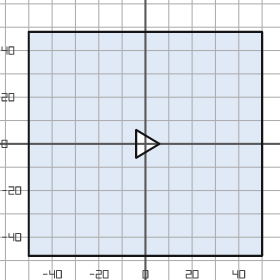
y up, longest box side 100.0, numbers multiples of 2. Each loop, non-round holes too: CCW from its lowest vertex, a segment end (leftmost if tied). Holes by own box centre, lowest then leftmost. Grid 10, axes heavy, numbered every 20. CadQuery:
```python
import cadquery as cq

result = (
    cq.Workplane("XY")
    .moveTo(-50.0, -48.0)
    .lineTo(50.0, -48.0)
    .lineTo(50.0, 48.0)
    .lineTo(-50.0, 48.0)
    .close()
    .moveTo(-4.0, -6.0)
    .lineTo(6.0, 0.0)
    .lineTo(-4.0, 6.0)
    .close()
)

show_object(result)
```